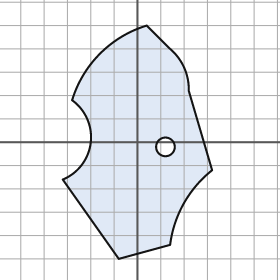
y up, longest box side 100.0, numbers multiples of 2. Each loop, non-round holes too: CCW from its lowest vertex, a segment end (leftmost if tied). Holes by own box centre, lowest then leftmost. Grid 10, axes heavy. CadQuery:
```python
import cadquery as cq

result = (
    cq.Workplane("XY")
    .moveTo(-8.0, -50.0)
    .lineTo(14.0, -44.0)
    .threePointArc((20.0, -26.0), (32.0, -12.0))
    .lineTo(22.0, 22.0)
    .threePointArc((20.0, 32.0), (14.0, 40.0))
    .lineTo(4.0, 50.0)
    .threePointArc((-16.0, 38.0), (-28.0, 18.0))
    .threePointArc((-20.0, 0.0), (-32.0, -16.0))
    .close()
    .moveTo(12.0, -2.0)
    .circle(4.0)
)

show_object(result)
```